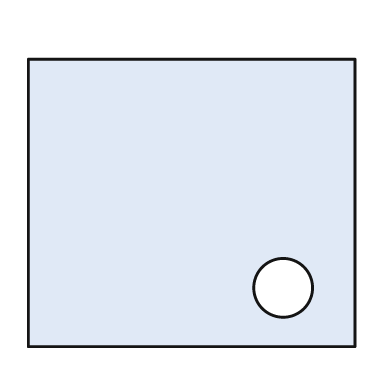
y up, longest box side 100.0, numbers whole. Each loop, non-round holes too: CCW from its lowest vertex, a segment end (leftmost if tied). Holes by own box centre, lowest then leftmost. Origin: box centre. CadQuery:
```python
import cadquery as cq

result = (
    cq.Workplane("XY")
    .moveTo(-50.0, -44.0)
    .lineTo(50.0, -44.0)
    .lineTo(50.0, 44.0)
    .lineTo(-50.0, 44.0)
    .close()
    .moveTo(28.0, -26.0)
    .circle(9.0)
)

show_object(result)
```